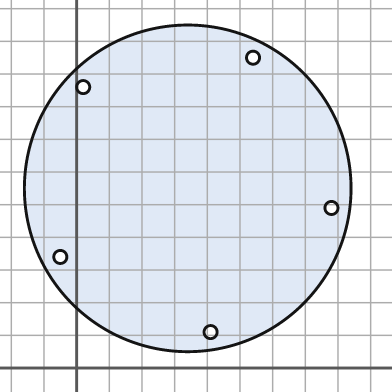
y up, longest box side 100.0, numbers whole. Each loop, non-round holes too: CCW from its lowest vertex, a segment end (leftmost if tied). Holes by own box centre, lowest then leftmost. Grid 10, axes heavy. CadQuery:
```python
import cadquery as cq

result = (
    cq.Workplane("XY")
    .moveTo(34.0, 55.0)
    .circle(50.0)
    .moveTo(41.0, 11.0)
    .circle(2.0)
    .moveTo(-5.0, 34.0)
    .circle(2.0)
    .moveTo(78.0, 49.0)
    .circle(2.0)
    .moveTo(2.0, 86.0)
    .circle(2.0)
    .moveTo(54.0, 95.0)
    .circle(2.0)
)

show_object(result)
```